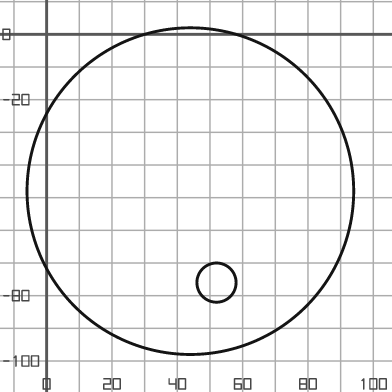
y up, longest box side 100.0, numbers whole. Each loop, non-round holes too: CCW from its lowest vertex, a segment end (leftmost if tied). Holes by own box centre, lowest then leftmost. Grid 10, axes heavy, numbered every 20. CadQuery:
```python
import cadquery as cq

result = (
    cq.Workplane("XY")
    .moveTo(44.0, -48.0)
    .circle(50.0)
    .moveTo(52.0, -76.0)
    .circle(6.0)
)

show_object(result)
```